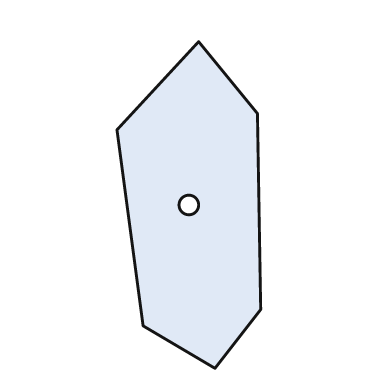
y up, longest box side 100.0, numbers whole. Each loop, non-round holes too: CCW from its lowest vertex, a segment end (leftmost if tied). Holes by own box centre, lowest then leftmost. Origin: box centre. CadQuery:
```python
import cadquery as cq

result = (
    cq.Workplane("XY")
    .moveTo(8.0, -50.0)
    .lineTo(22.0, -32.0)
    .lineTo(21.0, 28.0)
    .lineTo(3.0, 50.0)
    .lineTo(-22.0, 23.0)
    .lineTo(-14.0, -37.0)
    .close()
    .moveTo(0.0, 0.0)
    .circle(3.0)
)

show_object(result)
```